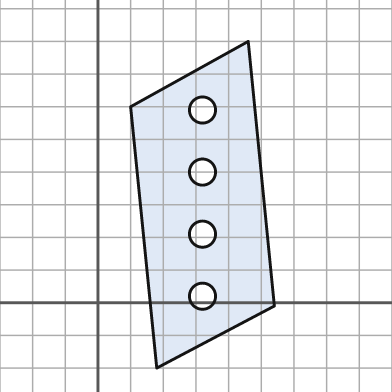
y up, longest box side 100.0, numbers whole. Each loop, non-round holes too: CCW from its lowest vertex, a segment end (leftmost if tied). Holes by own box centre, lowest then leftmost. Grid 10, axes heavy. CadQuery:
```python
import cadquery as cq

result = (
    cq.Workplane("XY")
    .moveTo(18.0, -20.0)
    .lineTo(54.0, -1.0)
    .lineTo(46.0, 80.0)
    .lineTo(10.0, 60.0)
    .close()
    .moveTo(32.0, 2.0)
    .circle(4.0)
    .moveTo(32.0, 21.0)
    .circle(4.0)
    .moveTo(32.0, 40.0)
    .circle(4.0)
    .moveTo(32.0, 59.0)
    .circle(4.0)
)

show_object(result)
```